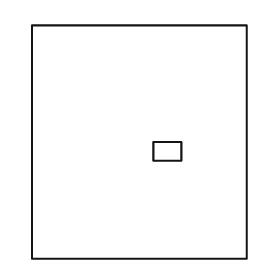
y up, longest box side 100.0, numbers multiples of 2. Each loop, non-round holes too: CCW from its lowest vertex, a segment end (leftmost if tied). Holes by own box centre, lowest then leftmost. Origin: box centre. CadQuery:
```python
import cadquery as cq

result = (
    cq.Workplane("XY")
    .moveTo(-46.0, -50.0)
    .lineTo(46.0, -50.0)
    .lineTo(46.0, 50.0)
    .lineTo(-46.0, 50.0)
    .close()
    .moveTo(6.0, -8.0)
    .lineTo(18.0, -8.0)
    .lineTo(18.0, 0.0)
    .lineTo(6.0, 0.0)
    .close()
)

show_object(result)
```